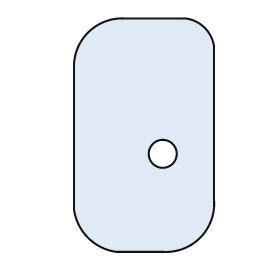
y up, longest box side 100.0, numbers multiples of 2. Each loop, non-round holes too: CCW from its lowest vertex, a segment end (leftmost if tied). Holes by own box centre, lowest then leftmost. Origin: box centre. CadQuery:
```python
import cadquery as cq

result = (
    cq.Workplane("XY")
    .moveTo(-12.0, -50.0)
    .lineTo(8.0, -50.0)
    .threePointArc((24.0, -44.0), (30.0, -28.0))
    .lineTo(30.0, 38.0)
    .threePointArc((26.0, 46.0), (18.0, 50.0))
    .lineTo(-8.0, 50.0)
    .threePointArc((-24.0, 44.0), (-30.0, 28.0))
    .lineTo(-30.0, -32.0)
    .threePointArc((-24.0, -44.0), (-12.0, -50.0))
    .close()
    .moveTo(8.0, -8.0)
    .circle(6.0)
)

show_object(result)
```